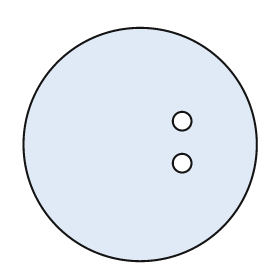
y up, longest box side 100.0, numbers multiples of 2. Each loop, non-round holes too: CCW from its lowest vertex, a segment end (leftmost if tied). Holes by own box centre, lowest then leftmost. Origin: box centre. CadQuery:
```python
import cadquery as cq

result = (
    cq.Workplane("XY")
    .moveTo(0.0, 0.0)
    .circle(50.0)
    .moveTo(18.0, -8.0)
    .circle(4.0)
    .moveTo(18.0, 10.0)
    .circle(4.0)
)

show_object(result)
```